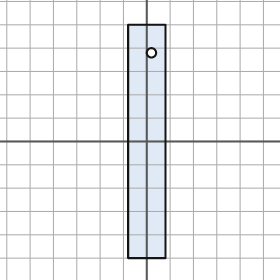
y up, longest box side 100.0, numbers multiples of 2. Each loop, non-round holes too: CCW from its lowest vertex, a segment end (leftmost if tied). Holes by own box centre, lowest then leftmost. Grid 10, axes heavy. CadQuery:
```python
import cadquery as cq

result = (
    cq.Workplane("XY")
    .moveTo(-8.0, -50.0)
    .lineTo(8.0, -50.0)
    .lineTo(8.0, 50.0)
    .lineTo(-8.0, 50.0)
    .close()
    .moveTo(2.0, 38.0)
    .circle(2.0)
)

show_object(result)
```